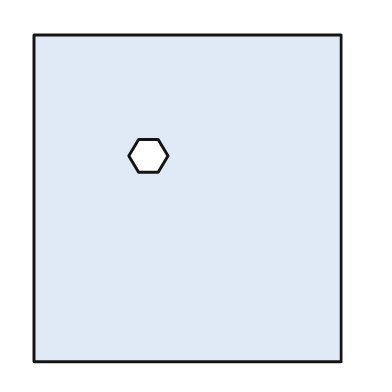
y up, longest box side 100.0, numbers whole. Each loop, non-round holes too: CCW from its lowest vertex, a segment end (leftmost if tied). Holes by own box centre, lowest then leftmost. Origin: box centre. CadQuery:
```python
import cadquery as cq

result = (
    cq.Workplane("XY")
    .moveTo(-47.0, -50.0)
    .lineTo(47.0, -50.0)
    .lineTo(47.0, 50.0)
    .lineTo(-47.0, 50.0)
    .close()
    .moveTo(-15.0, 8.0)
    .lineTo(-9.0, 8.0)
    .lineTo(-6.0, 13.0)
    .lineTo(-9.0, 18.0)
    .lineTo(-15.0, 18.0)
    .lineTo(-18.0, 13.0)
    .close()
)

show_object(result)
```